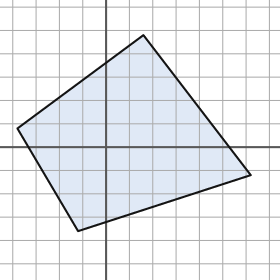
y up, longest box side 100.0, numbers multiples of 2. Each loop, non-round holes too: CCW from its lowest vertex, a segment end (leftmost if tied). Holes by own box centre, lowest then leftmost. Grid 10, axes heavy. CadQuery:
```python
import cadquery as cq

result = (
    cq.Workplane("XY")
    .moveTo(-12.0, -36.0)
    .lineTo(62.0, -12.0)
    .lineTo(16.0, 48.0)
    .lineTo(-38.0, 8.0)
    .close()
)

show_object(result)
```